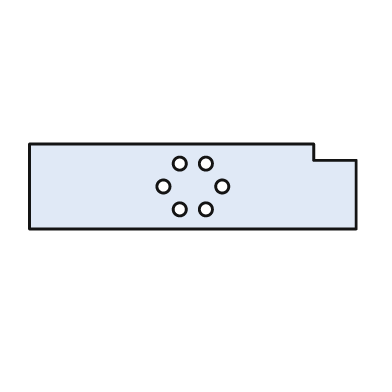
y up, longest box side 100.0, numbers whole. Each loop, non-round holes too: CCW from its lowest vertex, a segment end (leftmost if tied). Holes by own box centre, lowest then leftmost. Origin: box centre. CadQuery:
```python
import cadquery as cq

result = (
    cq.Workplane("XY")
    .moveTo(-50.0, -13.0)
    .lineTo(50.0, -13.0)
    .lineTo(50.0, 8.0)
    .lineTo(37.0, 8.0)
    .lineTo(37.0, 13.0)
    .lineTo(-50.0, 13.0)
    .close()
    .moveTo(-4.0, -7.0)
    .circle(2.0)
    .moveTo(4.0, -7.0)
    .circle(2.0)
    .moveTo(-9.0, 0.0)
    .circle(2.0)
    .moveTo(9.0, 0.0)
    .circle(2.0)
    .moveTo(-4.0, 7.0)
    .circle(2.0)
    .moveTo(4.0, 7.0)
    .circle(2.0)
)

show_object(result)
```